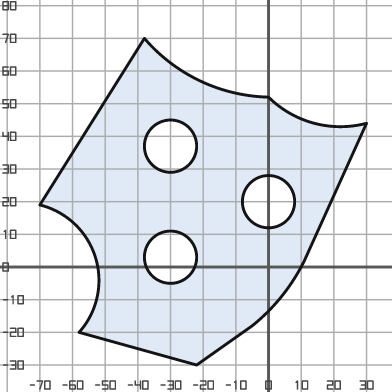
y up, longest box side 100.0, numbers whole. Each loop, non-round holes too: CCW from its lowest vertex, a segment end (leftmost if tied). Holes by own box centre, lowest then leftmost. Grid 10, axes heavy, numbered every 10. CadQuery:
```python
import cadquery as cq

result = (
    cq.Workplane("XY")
    .moveTo(-22.0, -30.0)
    .lineTo(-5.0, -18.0)
    .threePointArc((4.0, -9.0), (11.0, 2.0))
    .lineTo(30.0, 44.0)
    .threePointArc((14.0, 44.0), (0.0, 52.0))
    .threePointArc((-21.0, 57.0), (-38.0, 70.0))
    .lineTo(-70.0, 19.0)
    .threePointArc((-53.0, 3.0), (-58.0, -20.0))
    .close()
    .moveTo(-30.0, 3.0)
    .circle(8.0)
    .moveTo(0.0, 20.0)
    .circle(8.0)
    .moveTo(-30.0, 37.0)
    .circle(8.0)
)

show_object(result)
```